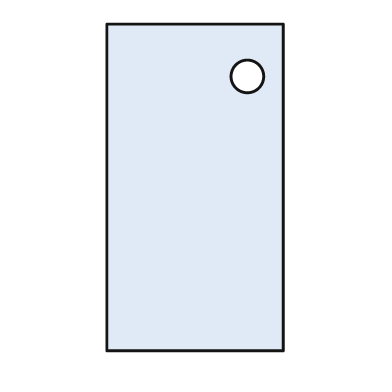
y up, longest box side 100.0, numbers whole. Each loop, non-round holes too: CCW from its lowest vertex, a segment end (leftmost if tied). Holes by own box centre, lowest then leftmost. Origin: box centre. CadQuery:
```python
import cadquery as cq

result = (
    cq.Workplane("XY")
    .moveTo(-27.0, -50.0)
    .lineTo(27.0, -50.0)
    .lineTo(27.0, 50.0)
    .lineTo(-27.0, 50.0)
    .close()
    .moveTo(16.0, 34.0)
    .circle(5.0)
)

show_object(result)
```